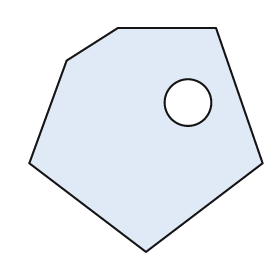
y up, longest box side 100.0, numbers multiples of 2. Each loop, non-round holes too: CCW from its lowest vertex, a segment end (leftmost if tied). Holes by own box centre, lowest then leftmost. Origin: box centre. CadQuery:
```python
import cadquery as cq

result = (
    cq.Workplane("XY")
    .moveTo(0.0, -48.0)
    .lineTo(50.0, -10.0)
    .lineTo(30.0, 48.0)
    .lineTo(-12.0, 48.0)
    .lineTo(-34.0, 34.0)
    .lineTo(-50.0, -10.0)
    .close()
    .moveTo(18.0, 16.0)
    .circle(10.0)
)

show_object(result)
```